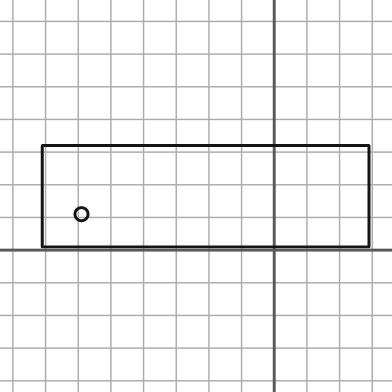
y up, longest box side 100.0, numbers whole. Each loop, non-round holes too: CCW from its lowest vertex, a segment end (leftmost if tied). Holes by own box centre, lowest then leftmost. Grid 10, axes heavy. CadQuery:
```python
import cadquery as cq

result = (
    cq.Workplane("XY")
    .moveTo(-71.0, 1.0)
    .lineTo(29.0, 1.0)
    .lineTo(29.0, 32.0)
    .lineTo(-71.0, 32.0)
    .close()
    .moveTo(-59.0, 11.0)
    .circle(2.0)
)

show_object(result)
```